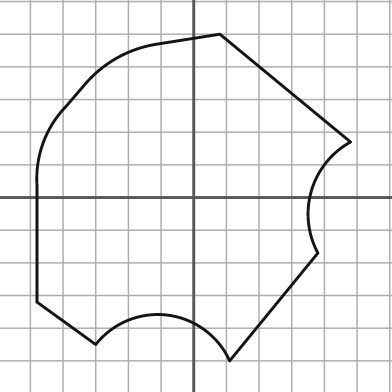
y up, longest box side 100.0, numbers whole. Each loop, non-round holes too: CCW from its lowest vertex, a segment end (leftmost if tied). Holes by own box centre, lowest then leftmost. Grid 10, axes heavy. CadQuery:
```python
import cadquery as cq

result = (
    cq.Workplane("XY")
    .moveTo(11.0, -50.0)
    .lineTo(38.0, -17.0)
    .threePointArc((36.0, 2.0), (48.0, 17.0))
    .lineTo(8.0, 50.0)
    .lineTo(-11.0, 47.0)
    .threePointArc((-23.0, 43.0), (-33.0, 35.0))
    .lineTo(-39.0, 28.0)
    .threePointArc((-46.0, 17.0), (-48.0, 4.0))
    .lineTo(-48.0, -32.0)
    .lineTo(-30.0, -45.0)
    .threePointArc((-8.0, -36.0), (11.0, -50.0))
    .close()
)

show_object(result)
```